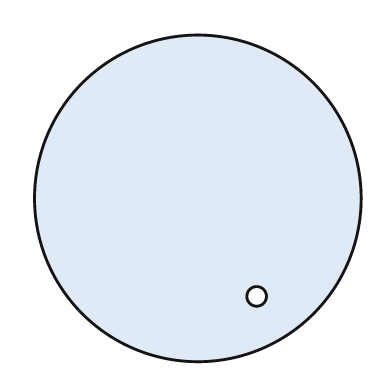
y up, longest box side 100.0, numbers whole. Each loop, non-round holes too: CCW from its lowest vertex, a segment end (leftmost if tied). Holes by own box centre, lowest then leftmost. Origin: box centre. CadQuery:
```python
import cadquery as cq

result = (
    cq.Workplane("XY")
    .moveTo(0.0, 0.0)
    .circle(50.0)
    .moveTo(18.0, -30.0)
    .circle(3.0)
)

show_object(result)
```